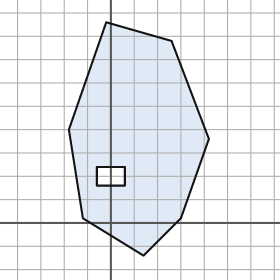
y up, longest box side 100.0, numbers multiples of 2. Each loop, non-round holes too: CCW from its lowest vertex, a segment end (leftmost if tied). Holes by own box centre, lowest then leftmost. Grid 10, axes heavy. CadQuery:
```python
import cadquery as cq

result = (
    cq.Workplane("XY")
    .moveTo(14.0, -14.0)
    .lineTo(30.0, 2.0)
    .lineTo(42.0, 36.0)
    .lineTo(26.0, 78.0)
    .lineTo(-2.0, 86.0)
    .lineTo(-18.0, 40.0)
    .lineTo(-12.0, 2.0)
    .close()
    .moveTo(-6.0, 16.0)
    .lineTo(6.0, 16.0)
    .lineTo(6.0, 24.0)
    .lineTo(-6.0, 24.0)
    .close()
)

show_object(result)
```